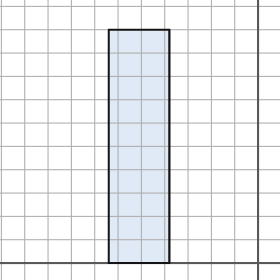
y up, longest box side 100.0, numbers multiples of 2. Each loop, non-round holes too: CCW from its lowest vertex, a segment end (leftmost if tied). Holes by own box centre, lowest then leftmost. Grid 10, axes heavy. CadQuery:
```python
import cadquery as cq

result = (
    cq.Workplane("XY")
    .moveTo(-64.0, 0.0)
    .lineTo(-38.0, 0.0)
    .lineTo(-38.0, 100.0)
    .lineTo(-64.0, 100.0)
    .close()
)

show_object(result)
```